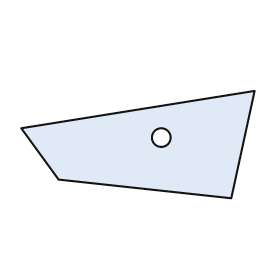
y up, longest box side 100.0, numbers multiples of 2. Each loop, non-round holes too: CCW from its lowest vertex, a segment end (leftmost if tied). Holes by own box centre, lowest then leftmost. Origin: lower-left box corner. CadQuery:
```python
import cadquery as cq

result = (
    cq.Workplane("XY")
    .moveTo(90.0, 0.0)
    .lineTo(100.0, 46.0)
    .lineTo(0.0, 30.0)
    .lineTo(16.0, 8.0)
    .close()
    .moveTo(60.0, 26.0)
    .circle(4.0)
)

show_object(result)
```